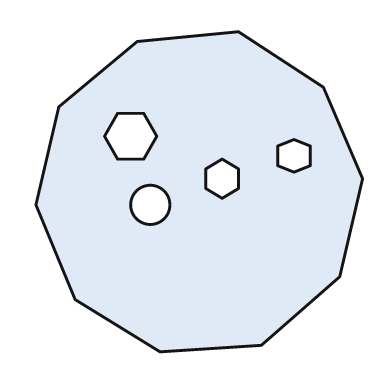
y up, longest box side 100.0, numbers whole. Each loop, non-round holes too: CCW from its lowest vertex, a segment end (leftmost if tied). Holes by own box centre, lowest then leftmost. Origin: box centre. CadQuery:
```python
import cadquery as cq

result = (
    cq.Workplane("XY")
    .moveTo(-12.0, -49.0)
    .lineTo(19.0, -47.0)
    .lineTo(43.0, -26.0)
    .lineTo(50.0, 4.0)
    .lineTo(38.0, 32.0)
    .lineTo(12.0, 49.0)
    .lineTo(-19.0, 46.0)
    .lineTo(-43.0, 26.0)
    .lineTo(-50.0, -4.0)
    .lineTo(-38.0, -33.0)
    .close()
    .moveTo(-15.0, -4.0)
    .circle(6.0)
    .moveTo(7.0, -2.0)
    .lineTo(12.0, 1.0)
    .lineTo(12.0, 7.0)
    .lineTo(7.0, 10.0)
    .lineTo(2.0, 7.0)
    .lineTo(2.0, 1.0)
    .close()
    .moveTo(29.0, 6.0)
    .lineTo(34.0, 8.0)
    .lineTo(34.0, 14.0)
    .lineTo(29.0, 16.0)
    .lineTo(24.0, 14.0)
    .lineTo(24.0, 8.0)
    .close()
    .moveTo(-25.0, 10.0)
    .lineTo(-17.0, 10.0)
    .lineTo(-13.0, 17.0)
    .lineTo(-17.0, 24.0)
    .lineTo(-25.0, 24.0)
    .lineTo(-29.0, 17.0)
    .close()
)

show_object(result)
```